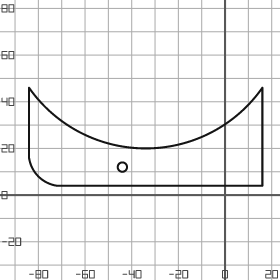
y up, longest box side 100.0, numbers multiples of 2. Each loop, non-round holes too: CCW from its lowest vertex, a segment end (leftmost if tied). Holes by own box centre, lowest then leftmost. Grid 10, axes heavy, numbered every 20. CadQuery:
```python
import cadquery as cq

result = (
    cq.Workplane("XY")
    .moveTo(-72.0, 4.0)
    .lineTo(16.0, 4.0)
    .lineTo(16.0, 46.0)
    .threePointArc((-34.0, 20.0), (-84.0, 46.0))
    .lineTo(-84.0, 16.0)
    .threePointArc((-80.0, 8.0), (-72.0, 4.0))
    .close()
    .moveTo(-44.0, 12.0)
    .circle(2.0)
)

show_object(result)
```